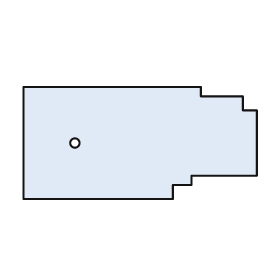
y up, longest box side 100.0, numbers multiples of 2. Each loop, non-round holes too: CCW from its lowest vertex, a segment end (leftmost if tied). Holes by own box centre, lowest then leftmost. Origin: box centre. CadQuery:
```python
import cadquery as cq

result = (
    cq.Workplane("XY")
    .moveTo(-50.0, -24.0)
    .lineTo(14.0, -24.0)
    .lineTo(14.0, -18.0)
    .lineTo(22.0, -18.0)
    .lineTo(22.0, -14.0)
    .lineTo(50.0, -14.0)
    .lineTo(50.0, 14.0)
    .lineTo(44.0, 14.0)
    .lineTo(44.0, 20.0)
    .lineTo(26.0, 20.0)
    .lineTo(26.0, 24.0)
    .lineTo(-50.0, 24.0)
    .close()
    .moveTo(-28.0, 0.0)
    .circle(2.0)
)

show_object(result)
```